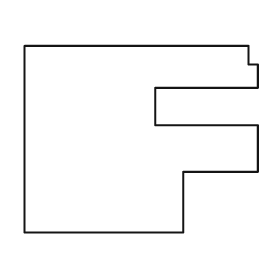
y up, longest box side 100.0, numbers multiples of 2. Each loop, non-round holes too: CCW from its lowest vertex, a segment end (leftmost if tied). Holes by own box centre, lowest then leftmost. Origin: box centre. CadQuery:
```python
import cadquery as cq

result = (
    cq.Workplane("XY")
    .moveTo(-50.0, -40.0)
    .lineTo(18.0, -40.0)
    .lineTo(18.0, -14.0)
    .lineTo(50.0, -14.0)
    .lineTo(50.0, 6.0)
    .lineTo(6.0, 6.0)
    .lineTo(6.0, 22.0)
    .lineTo(50.0, 22.0)
    .lineTo(50.0, 32.0)
    .lineTo(46.0, 32.0)
    .lineTo(46.0, 40.0)
    .lineTo(-50.0, 40.0)
    .close()
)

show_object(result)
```